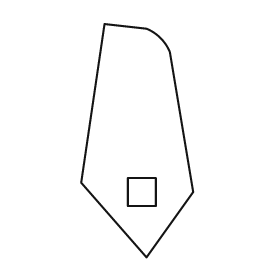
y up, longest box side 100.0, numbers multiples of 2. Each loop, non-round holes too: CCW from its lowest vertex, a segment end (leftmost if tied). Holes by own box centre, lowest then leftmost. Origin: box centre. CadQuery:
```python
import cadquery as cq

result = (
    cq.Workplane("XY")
    .moveTo(4.0, -50.0)
    .lineTo(24.0, -22.0)
    .lineTo(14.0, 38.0)
    .threePointArc((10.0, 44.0), (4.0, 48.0))
    .lineTo(-14.0, 50.0)
    .lineTo(-24.0, -18.0)
    .close()
    .moveTo(-4.0, -28.0)
    .lineTo(8.0, -28.0)
    .lineTo(8.0, -16.0)
    .lineTo(-4.0, -16.0)
    .close()
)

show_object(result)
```